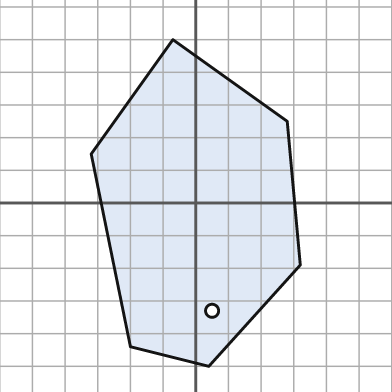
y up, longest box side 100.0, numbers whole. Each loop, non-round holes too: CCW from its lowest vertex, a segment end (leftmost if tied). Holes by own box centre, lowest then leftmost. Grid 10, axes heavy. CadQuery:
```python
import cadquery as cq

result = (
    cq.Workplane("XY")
    .moveTo(4.0, -50.0)
    .lineTo(32.0, -19.0)
    .lineTo(28.0, 25.0)
    .lineTo(-7.0, 50.0)
    .lineTo(-32.0, 15.0)
    .lineTo(-20.0, -44.0)
    .close()
    .moveTo(5.0, -33.0)
    .circle(2.0)
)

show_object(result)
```